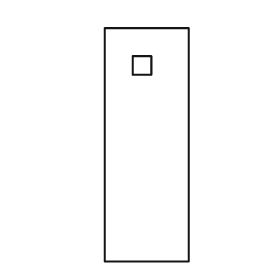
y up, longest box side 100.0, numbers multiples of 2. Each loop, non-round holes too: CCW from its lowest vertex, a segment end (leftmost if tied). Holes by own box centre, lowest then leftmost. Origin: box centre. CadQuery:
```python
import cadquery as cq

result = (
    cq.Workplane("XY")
    .moveTo(-18.0, -50.0)
    .lineTo(18.0, -50.0)
    .lineTo(18.0, 50.0)
    .lineTo(-18.0, 50.0)
    .close()
    .moveTo(-6.0, 30.0)
    .lineTo(2.0, 30.0)
    .lineTo(2.0, 38.0)
    .lineTo(-6.0, 38.0)
    .close()
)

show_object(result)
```